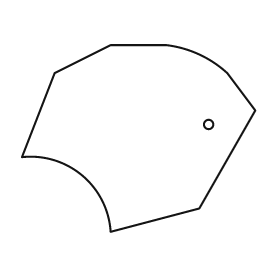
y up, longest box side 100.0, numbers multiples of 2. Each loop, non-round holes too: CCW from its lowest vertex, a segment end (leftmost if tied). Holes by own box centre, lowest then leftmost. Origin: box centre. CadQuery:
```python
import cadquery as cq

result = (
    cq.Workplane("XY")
    .moveTo(-12.0, -40.0)
    .lineTo(26.0, -30.0)
    .lineTo(50.0, 12.0)
    .lineTo(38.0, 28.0)
    .threePointArc((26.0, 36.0), (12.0, 40.0))
    .lineTo(-12.0, 40.0)
    .lineTo(-36.0, 28.0)
    .lineTo(-50.0, -8.0)
    .threePointArc((-24.0, -16.0), (-12.0, -40.0))
    .close()
    .moveTo(30.0, 6.0)
    .circle(2.0)
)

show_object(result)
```